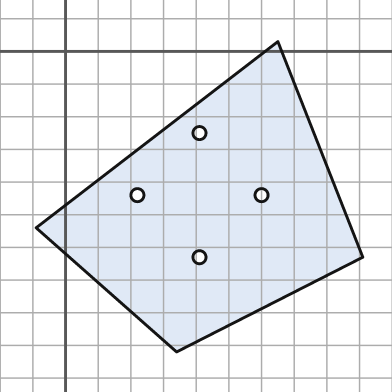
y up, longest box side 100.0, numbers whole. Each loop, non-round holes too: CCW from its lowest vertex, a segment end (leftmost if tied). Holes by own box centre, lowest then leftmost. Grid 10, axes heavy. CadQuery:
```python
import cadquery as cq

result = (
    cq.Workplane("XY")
    .moveTo(34.0, -92.0)
    .lineTo(91.0, -63.0)
    .lineTo(65.0, 3.0)
    .lineTo(-9.0, -54.0)
    .close()
    .moveTo(41.0, -63.0)
    .circle(2.0)
    .moveTo(22.0, -44.0)
    .circle(2.0)
    .moveTo(60.0, -44.0)
    .circle(2.0)
    .moveTo(41.0, -25.0)
    .circle(2.0)
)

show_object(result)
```